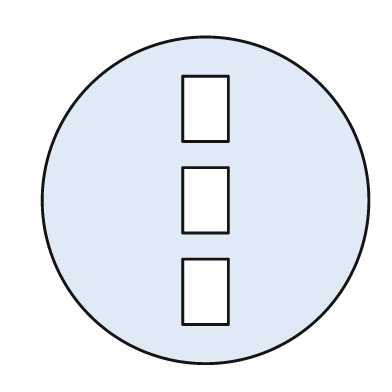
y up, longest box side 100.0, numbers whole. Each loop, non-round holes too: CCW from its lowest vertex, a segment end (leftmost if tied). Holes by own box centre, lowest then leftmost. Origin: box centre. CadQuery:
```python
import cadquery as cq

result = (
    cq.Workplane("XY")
    .moveTo(0.0, 0.0)
    .circle(50.0)
    .moveTo(-7.0, -38.0)
    .lineTo(7.0, -38.0)
    .lineTo(7.0, -18.0)
    .lineTo(-7.0, -18.0)
    .close()
    .moveTo(-7.0, -10.0)
    .lineTo(7.0, -10.0)
    .lineTo(7.0, 10.0)
    .lineTo(-7.0, 10.0)
    .close()
    .moveTo(-7.0, 18.0)
    .lineTo(7.0, 18.0)
    .lineTo(7.0, 38.0)
    .lineTo(-7.0, 38.0)
    .close()
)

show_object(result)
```